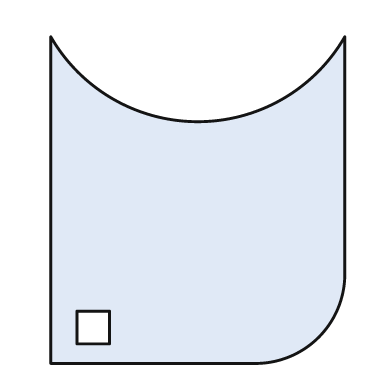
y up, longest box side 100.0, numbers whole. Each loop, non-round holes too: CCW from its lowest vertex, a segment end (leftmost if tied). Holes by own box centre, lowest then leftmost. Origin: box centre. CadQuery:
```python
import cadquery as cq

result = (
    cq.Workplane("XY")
    .moveTo(-45.0, -50.0)
    .lineTo(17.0, -50.0)
    .threePointArc((37.0, -42.0), (45.0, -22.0))
    .lineTo(45.0, 50.0)
    .threePointArc((0.0, 24.0), (-45.0, 50.0))
    .close()
    .moveTo(-37.0, -44.0)
    .lineTo(-27.0, -44.0)
    .lineTo(-27.0, -34.0)
    .lineTo(-37.0, -34.0)
    .close()
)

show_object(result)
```